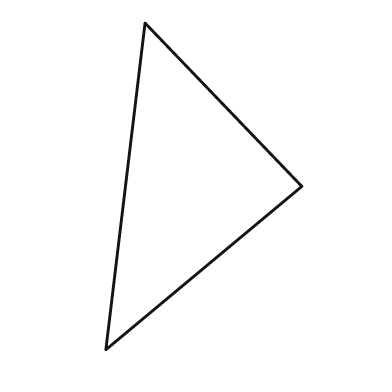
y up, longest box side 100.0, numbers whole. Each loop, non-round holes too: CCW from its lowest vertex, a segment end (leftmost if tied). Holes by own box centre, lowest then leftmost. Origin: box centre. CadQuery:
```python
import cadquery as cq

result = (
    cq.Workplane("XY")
    .moveTo(-30.0, -50.0)
    .lineTo(30.0, 0.0)
    .lineTo(-18.0, 50.0)
    .close()
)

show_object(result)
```